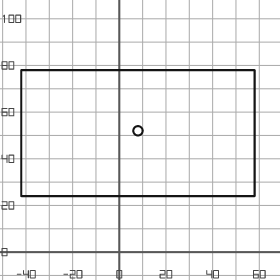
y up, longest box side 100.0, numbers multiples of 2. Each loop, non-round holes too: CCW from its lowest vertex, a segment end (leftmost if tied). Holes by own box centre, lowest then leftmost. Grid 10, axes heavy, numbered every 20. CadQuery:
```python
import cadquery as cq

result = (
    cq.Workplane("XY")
    .moveTo(-42.0, 24.0)
    .lineTo(58.0, 24.0)
    .lineTo(58.0, 78.0)
    .lineTo(-42.0, 78.0)
    .close()
    .moveTo(8.0, 52.0)
    .circle(2.0)
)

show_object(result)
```